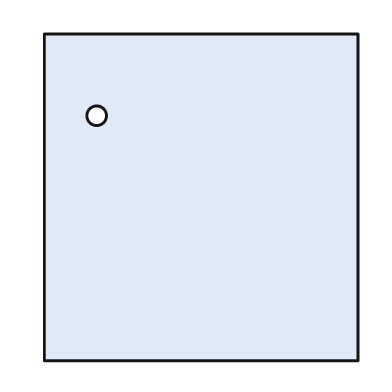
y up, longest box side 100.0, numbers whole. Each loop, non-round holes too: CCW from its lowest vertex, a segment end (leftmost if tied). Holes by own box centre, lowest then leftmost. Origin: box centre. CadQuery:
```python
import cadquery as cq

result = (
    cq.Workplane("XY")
    .moveTo(-48.0, -50.0)
    .lineTo(48.0, -50.0)
    .lineTo(48.0, 50.0)
    .lineTo(-48.0, 50.0)
    .close()
    .moveTo(-32.0, 25.0)
    .circle(3.0)
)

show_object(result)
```